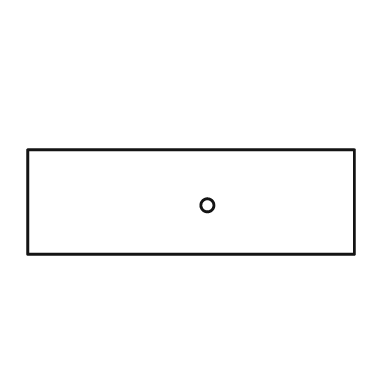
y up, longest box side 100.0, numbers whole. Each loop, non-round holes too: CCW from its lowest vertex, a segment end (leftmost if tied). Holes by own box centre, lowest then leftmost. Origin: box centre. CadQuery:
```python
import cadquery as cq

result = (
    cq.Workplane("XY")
    .moveTo(-50.0, -16.0)
    .lineTo(50.0, -16.0)
    .lineTo(50.0, 16.0)
    .lineTo(-50.0, 16.0)
    .close()
    .moveTo(5.0, -1.0)
    .circle(2.0)
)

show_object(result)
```